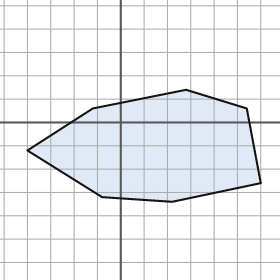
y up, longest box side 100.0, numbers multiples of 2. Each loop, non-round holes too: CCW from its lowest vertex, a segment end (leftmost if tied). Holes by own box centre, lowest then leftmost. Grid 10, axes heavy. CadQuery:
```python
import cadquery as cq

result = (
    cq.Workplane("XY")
    .moveTo(22.0, -34.0)
    .lineTo(60.0, -26.0)
    .lineTo(54.0, 6.0)
    .lineTo(28.0, 14.0)
    .lineTo(-12.0, 6.0)
    .lineTo(-40.0, -12.0)
    .lineTo(-8.0, -32.0)
    .close()
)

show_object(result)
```